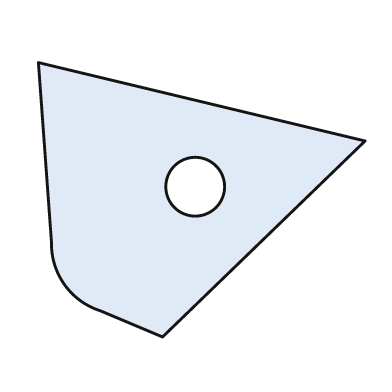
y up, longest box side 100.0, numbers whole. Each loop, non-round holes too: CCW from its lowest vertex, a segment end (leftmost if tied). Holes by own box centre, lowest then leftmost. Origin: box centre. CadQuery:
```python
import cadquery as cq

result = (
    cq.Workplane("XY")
    .moveTo(-12.0, -42.0)
    .lineTo(50.0, 18.0)
    .lineTo(-50.0, 42.0)
    .lineTo(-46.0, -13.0)
    .threePointArc((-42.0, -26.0), (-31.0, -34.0))
    .close()
    .moveTo(-2.0, 4.0)
    .circle(9.0)
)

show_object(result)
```